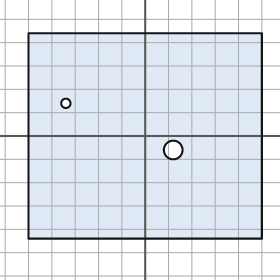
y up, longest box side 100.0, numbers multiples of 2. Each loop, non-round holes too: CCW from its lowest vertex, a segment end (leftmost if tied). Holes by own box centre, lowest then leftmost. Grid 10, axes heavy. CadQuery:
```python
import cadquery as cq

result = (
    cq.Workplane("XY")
    .moveTo(-50.0, -44.0)
    .lineTo(50.0, -44.0)
    .lineTo(50.0, 44.0)
    .lineTo(-50.0, 44.0)
    .close()
    .moveTo(12.0, -6.0)
    .circle(4.0)
    .moveTo(-34.0, 14.0)
    .circle(2.0)
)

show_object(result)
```